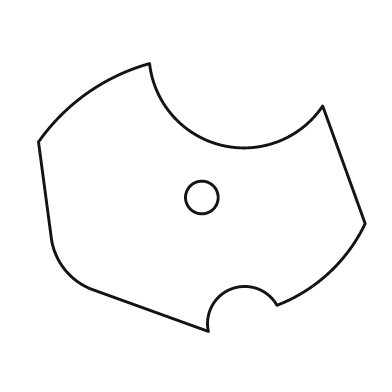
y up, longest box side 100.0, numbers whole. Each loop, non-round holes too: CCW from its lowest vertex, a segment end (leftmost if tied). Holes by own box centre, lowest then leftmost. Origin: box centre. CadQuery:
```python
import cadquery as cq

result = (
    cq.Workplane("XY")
    .moveTo(2.0, -41.0)
    .threePointArc((9.0, -28.0), (23.0, -33.0))
    .threePointArc((39.0, -23.0), (50.0, -8.0))
    .lineTo(37.0, 28.0)
    .threePointArc((6.0, 16.0), (-16.0, 41.0))
    .threePointArc((-35.0, 32.0), (-50.0, 17.0))
    .lineTo(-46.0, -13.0)
    .threePointArc((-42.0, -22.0), (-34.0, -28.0))
    .close()
    .moveTo(0.0, 0.0)
    .circle(5.0)
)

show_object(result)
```